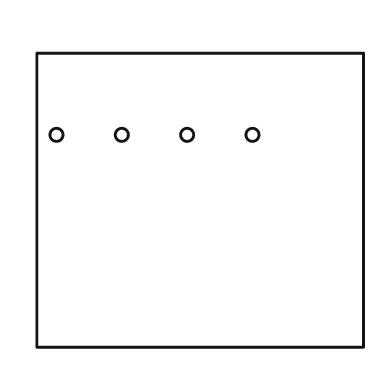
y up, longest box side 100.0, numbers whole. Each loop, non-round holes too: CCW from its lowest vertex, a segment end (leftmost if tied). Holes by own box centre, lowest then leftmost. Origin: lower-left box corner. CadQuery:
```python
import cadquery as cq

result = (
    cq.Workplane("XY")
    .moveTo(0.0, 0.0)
    .lineTo(100.0, 0.0)
    .lineTo(100.0, 90.0)
    .lineTo(0.0, 90.0)
    .close()
    .moveTo(6.0, 65.0)
    .circle(2.0)
    .moveTo(26.0, 65.0)
    .circle(2.0)
    .moveTo(46.0, 65.0)
    .circle(2.0)
    .moveTo(66.0, 65.0)
    .circle(2.0)
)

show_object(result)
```